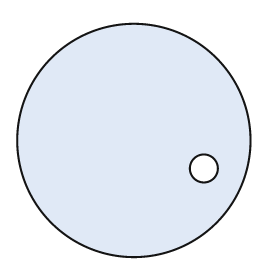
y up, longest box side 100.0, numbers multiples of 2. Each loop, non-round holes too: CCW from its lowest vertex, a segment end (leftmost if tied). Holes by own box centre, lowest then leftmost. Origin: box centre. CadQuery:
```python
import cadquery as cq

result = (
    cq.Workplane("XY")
    .moveTo(0.0, 0.0)
    .circle(50.0)
    .moveTo(30.0, -12.0)
    .circle(6.0)
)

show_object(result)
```